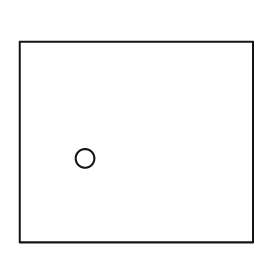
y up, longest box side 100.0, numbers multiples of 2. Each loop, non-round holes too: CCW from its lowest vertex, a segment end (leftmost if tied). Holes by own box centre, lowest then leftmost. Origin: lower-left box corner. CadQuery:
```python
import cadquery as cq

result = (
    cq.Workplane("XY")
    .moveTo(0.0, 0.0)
    .lineTo(100.0, 0.0)
    .lineTo(100.0, 86.0)
    .lineTo(0.0, 86.0)
    .close()
    .moveTo(28.0, 36.0)
    .circle(4.0)
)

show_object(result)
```